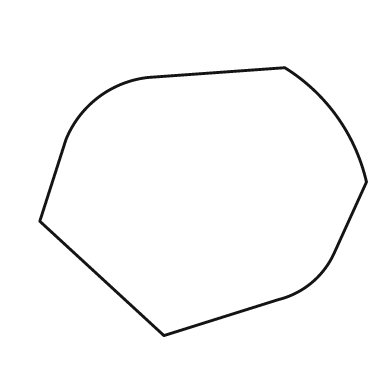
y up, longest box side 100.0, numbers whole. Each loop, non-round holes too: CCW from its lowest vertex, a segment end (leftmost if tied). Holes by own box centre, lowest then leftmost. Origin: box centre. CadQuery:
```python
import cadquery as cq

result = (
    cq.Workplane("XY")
    .moveTo(-12.0, -41.0)
    .lineTo(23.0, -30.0)
    .threePointArc((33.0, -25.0), (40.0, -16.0))
    .lineTo(50.0, 6.0)
    .threePointArc((41.0, 26.0), (25.0, 41.0))
    .lineTo(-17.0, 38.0)
    .threePointArc((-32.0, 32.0), (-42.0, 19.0))
    .lineTo(-50.0, -6.0)
    .close()
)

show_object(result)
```